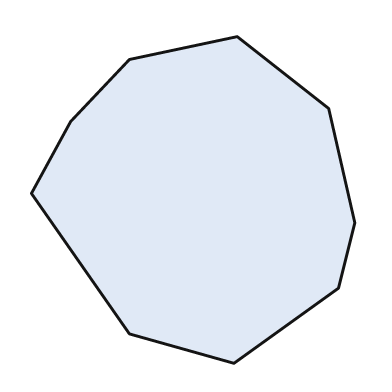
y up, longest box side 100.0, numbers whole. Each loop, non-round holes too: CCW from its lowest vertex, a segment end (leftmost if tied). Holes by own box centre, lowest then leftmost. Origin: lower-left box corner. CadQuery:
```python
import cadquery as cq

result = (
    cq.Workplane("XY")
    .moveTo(62.0, 0.0)
    .lineTo(94.0, 23.0)
    .lineTo(99.0, 43.0)
    .lineTo(91.0, 78.0)
    .lineTo(63.0, 100.0)
    .lineTo(30.0, 93.0)
    .lineTo(12.0, 74.0)
    .lineTo(0.0, 52.0)
    .lineTo(30.0, 9.0)
    .close()
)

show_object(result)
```